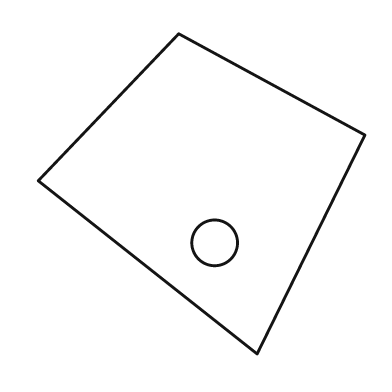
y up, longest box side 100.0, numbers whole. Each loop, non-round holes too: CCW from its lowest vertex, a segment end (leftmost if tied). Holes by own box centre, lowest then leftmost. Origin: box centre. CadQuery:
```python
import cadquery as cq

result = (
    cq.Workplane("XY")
    .moveTo(17.0, -49.0)
    .lineTo(50.0, 18.0)
    .lineTo(-7.0, 49.0)
    .lineTo(-50.0, 4.0)
    .close()
    .moveTo(4.0, -15.0)
    .circle(7.0)
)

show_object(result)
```